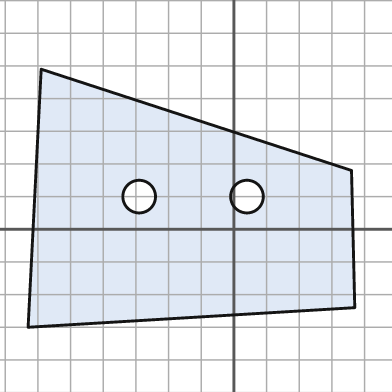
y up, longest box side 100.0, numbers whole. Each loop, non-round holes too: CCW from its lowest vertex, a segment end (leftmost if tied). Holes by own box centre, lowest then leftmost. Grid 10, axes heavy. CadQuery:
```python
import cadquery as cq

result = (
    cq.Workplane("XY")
    .moveTo(-63.0, -30.0)
    .lineTo(37.0, -24.0)
    .lineTo(36.0, 18.0)
    .lineTo(-59.0, 49.0)
    .close()
    .moveTo(-29.0, 10.0)
    .circle(5.0)
    .moveTo(4.0, 10.0)
    .circle(5.0)
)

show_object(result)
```